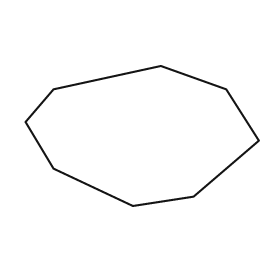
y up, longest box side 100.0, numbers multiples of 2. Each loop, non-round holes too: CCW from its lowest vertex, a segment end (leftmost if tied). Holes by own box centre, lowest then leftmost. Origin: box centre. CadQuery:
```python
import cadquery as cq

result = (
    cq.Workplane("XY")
    .moveTo(-4.0, -30.0)
    .lineTo(22.0, -26.0)
    .lineTo(50.0, -2.0)
    .lineTo(36.0, 20.0)
    .lineTo(8.0, 30.0)
    .lineTo(-38.0, 20.0)
    .lineTo(-50.0, 6.0)
    .lineTo(-38.0, -14.0)
    .close()
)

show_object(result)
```